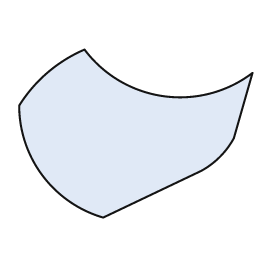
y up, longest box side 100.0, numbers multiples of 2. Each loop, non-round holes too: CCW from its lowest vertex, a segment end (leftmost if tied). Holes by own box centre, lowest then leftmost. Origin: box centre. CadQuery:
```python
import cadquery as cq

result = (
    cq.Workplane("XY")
    .moveTo(-14.0, -36.0)
    .lineTo(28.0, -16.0)
    .threePointArc((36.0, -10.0), (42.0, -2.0))
    .lineTo(50.0, 26.0)
    .threePointArc((12.0, 16.0), (-22.0, 36.0))
    .threePointArc((-38.0, 26.0), (-50.0, 12.0))
    .threePointArc((-40.0, -18.0), (-14.0, -36.0))
    .close()
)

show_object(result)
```